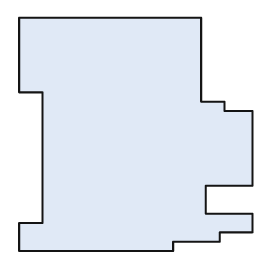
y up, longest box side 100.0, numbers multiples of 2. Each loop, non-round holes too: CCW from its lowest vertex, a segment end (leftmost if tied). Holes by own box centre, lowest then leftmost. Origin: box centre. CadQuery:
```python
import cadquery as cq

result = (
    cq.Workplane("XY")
    .moveTo(-50.0, -50.0)
    .lineTo(16.0, -50.0)
    .lineTo(16.0, -46.0)
    .lineTo(36.0, -46.0)
    .lineTo(36.0, -42.0)
    .lineTo(50.0, -42.0)
    .lineTo(50.0, -34.0)
    .lineTo(30.0, -34.0)
    .lineTo(30.0, -22.0)
    .lineTo(50.0, -22.0)
    .lineTo(50.0, 10.0)
    .lineTo(38.0, 10.0)
    .lineTo(38.0, 14.0)
    .lineTo(28.0, 14.0)
    .lineTo(28.0, 50.0)
    .lineTo(-50.0, 50.0)
    .lineTo(-50.0, 18.0)
    .lineTo(-40.0, 18.0)
    .lineTo(-40.0, -38.0)
    .lineTo(-50.0, -38.0)
    .close()
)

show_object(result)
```